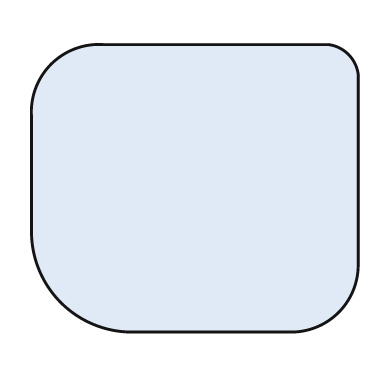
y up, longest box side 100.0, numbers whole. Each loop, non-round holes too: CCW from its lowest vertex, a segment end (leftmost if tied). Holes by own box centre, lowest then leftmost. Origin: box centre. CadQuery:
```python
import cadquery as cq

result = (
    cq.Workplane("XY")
    .moveTo(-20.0, -44.0)
    .lineTo(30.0, -44.0)
    .threePointArc((44.0, -38.0), (50.0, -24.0))
    .lineTo(50.0, 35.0)
    .threePointArc((47.0, 41.0), (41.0, 44.0))
    .lineTo(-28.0, 44.0)
    .threePointArc((-44.0, 38.0), (-50.0, 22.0))
    .lineTo(-50.0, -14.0)
    .threePointArc((-41.0, -35.0), (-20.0, -44.0))
    .close()
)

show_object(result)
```